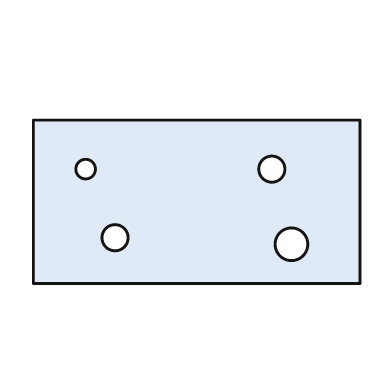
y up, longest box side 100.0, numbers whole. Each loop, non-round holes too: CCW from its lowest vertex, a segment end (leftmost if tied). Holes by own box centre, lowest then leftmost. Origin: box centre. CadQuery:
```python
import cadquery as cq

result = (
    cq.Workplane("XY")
    .moveTo(-50.0, -25.0)
    .lineTo(50.0, -25.0)
    .lineTo(50.0, 25.0)
    .lineTo(-50.0, 25.0)
    .close()
    .moveTo(29.0, -13.0)
    .circle(5.0)
    .moveTo(-25.0, -11.0)
    .circle(4.0)
    .moveTo(-34.0, 10.0)
    .circle(3.0)
    .moveTo(23.0, 10.0)
    .circle(4.0)
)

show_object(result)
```